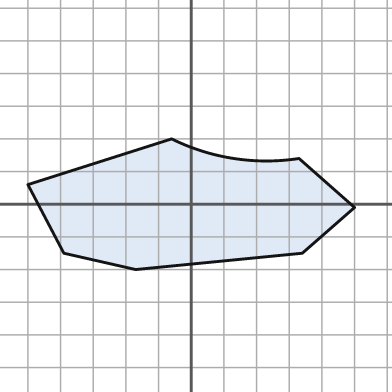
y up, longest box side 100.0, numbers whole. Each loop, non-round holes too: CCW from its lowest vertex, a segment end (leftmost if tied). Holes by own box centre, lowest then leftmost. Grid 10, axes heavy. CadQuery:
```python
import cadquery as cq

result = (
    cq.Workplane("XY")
    .moveTo(-17.0, -20.0)
    .lineTo(34.0, -15.0)
    .lineTo(50.0, -1.0)
    .lineTo(33.0, 14.0)
    .threePointArc((13.0, 14.0), (-6.0, 20.0))
    .lineTo(-50.0, 6.0)
    .lineTo(-39.0, -15.0)
    .close()
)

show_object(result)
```